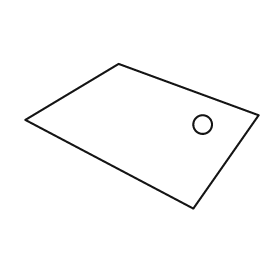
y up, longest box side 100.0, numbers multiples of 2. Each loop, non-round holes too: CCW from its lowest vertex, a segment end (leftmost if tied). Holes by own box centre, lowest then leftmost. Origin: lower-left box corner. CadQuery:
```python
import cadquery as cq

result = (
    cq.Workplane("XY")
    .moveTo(72.0, 0.0)
    .lineTo(100.0, 40.0)
    .lineTo(40.0, 62.0)
    .lineTo(0.0, 38.0)
    .close()
    .moveTo(76.0, 36.0)
    .circle(4.0)
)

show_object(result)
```